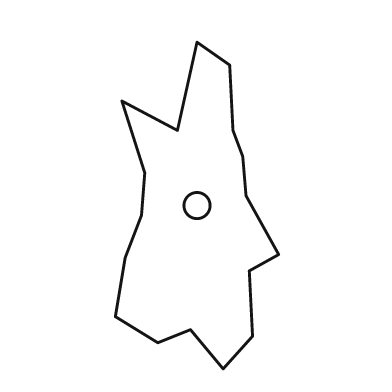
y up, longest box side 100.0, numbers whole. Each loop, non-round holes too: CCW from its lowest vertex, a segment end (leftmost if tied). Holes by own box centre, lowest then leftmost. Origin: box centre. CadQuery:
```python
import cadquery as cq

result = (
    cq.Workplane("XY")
    .moveTo(8.0, -50.0)
    .lineTo(17.0, -40.0)
    .lineTo(16.0, -20.0)
    .lineTo(25.0, -15.0)
    .lineTo(15.0, 3.0)
    .lineTo(14.0, 15.0)
    .lineTo(11.0, 23.0)
    .lineTo(10.0, 43.0)
    .lineTo(0.0, 50.0)
    .lineTo(-6.0, 23.0)
    .lineTo(-23.0, 32.0)
    .lineTo(-16.0, 10.0)
    .lineTo(-17.0, -3.0)
    .lineTo(-22.0, -16.0)
    .lineTo(-25.0, -34.0)
    .lineTo(-12.0, -42.0)
    .lineTo(-2.0, -38.0)
    .close()
    .moveTo(0.0, 0.0)
    .circle(4.0)
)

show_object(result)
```